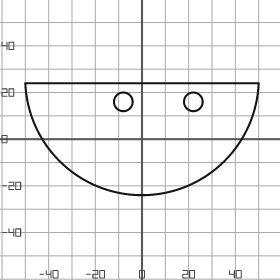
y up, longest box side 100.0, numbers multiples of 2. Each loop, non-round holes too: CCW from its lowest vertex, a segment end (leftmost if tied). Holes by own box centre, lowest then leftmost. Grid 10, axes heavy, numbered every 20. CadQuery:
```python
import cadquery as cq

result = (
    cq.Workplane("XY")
    .moveTo(-50.0, 24.0)
    .threePointArc((0.0, -24.0), (50.0, 24.0))
    .close()
    .moveTo(-8.0, 16.0)
    .circle(4.0)
    .moveTo(22.0, 16.0)
    .circle(4.0)
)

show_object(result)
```